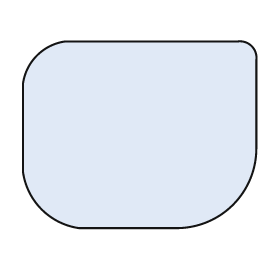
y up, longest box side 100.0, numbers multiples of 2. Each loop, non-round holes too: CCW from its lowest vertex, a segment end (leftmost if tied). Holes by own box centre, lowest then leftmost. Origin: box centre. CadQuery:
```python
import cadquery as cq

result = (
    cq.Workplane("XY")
    .moveTo(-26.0, -40.0)
    .lineTo(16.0, -40.0)
    .threePointArc((40.0, -30.0), (50.0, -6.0))
    .lineTo(50.0, 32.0)
    .threePointArc((48.0, 38.0), (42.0, 40.0))
    .lineTo(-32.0, 40.0)
    .threePointArc((-44.0, 34.0), (-50.0, 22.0))
    .lineTo(-50.0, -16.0)
    .threePointArc((-42.0, -32.0), (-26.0, -40.0))
    .close()
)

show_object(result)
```